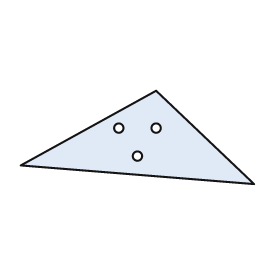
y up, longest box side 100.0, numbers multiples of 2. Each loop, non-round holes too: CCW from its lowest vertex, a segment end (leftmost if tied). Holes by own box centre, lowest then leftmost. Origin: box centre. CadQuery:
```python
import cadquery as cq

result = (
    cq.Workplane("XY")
    .moveTo(50.0, -20.0)
    .lineTo(8.0, 20.0)
    .lineTo(-50.0, -12.0)
    .close()
    .moveTo(0.0, -8.0)
    .circle(2.0)
    .moveTo(-8.0, 4.0)
    .circle(2.0)
    .moveTo(8.0, 4.0)
    .circle(2.0)
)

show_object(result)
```